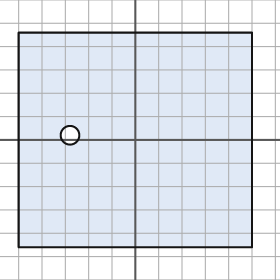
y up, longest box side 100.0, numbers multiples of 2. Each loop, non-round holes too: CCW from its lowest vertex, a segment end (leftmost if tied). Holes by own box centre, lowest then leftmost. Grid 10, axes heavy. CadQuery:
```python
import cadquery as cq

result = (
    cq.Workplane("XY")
    .moveTo(-50.0, -46.0)
    .lineTo(50.0, -46.0)
    .lineTo(50.0, 46.0)
    .lineTo(-50.0, 46.0)
    .close()
    .moveTo(-28.0, 2.0)
    .circle(4.0)
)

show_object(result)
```